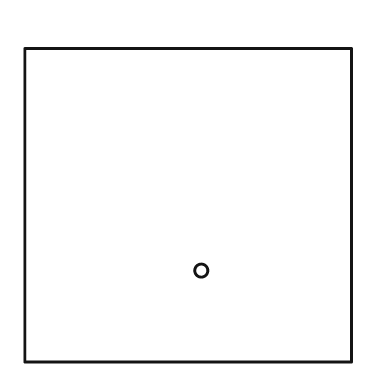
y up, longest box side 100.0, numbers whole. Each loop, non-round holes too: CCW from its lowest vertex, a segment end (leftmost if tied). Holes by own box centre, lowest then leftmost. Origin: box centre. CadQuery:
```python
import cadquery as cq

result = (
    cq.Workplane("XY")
    .moveTo(-50.0, -48.0)
    .lineTo(50.0, -48.0)
    .lineTo(50.0, 48.0)
    .lineTo(-50.0, 48.0)
    .close()
    .moveTo(4.0, -20.0)
    .circle(2.0)
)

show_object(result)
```